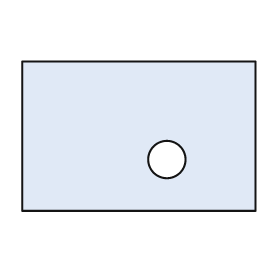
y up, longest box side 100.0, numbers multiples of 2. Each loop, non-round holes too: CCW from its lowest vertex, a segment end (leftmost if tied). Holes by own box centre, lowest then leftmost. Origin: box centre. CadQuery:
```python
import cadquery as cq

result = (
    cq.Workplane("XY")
    .moveTo(-50.0, -32.0)
    .lineTo(50.0, -32.0)
    .lineTo(50.0, 32.0)
    .lineTo(-50.0, 32.0)
    .close()
    .moveTo(12.0, -10.0)
    .circle(8.0)
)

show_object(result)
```